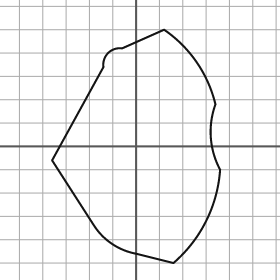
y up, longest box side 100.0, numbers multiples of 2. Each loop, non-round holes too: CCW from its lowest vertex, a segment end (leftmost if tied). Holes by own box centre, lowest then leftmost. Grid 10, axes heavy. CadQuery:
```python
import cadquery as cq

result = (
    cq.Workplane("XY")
    .moveTo(16.0, -50.0)
    .threePointArc((30.0, -32.0), (36.0, -10.0))
    .threePointArc((32.0, 4.0), (34.0, 18.0))
    .threePointArc((26.0, 36.0), (12.0, 50.0))
    .lineTo(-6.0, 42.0)
    .threePointArc((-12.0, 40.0), (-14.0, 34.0))
    .lineTo(-36.0, -6.0)
    .lineTo(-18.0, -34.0)
    .threePointArc((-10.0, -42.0), (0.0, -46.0))
    .close()
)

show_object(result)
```